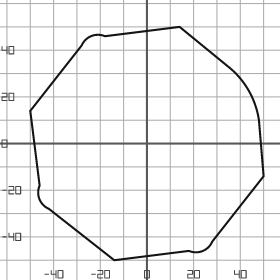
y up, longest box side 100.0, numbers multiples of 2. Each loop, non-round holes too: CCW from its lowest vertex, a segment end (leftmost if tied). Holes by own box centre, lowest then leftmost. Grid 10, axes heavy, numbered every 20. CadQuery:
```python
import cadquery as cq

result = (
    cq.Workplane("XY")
    .moveTo(-14.0, -50.0)
    .lineTo(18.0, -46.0)
    .threePointArc((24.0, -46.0), (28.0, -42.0))
    .lineTo(50.0, -14.0)
    .lineTo(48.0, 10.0)
    .threePointArc((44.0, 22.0), (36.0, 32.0))
    .lineTo(14.0, 50.0)
    .lineTo(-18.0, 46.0)
    .threePointArc((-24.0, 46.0), (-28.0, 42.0))
    .lineTo(-50.0, 14.0)
    .lineTo(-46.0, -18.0)
    .threePointArc((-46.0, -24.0), (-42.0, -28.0))
    .close()
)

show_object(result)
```